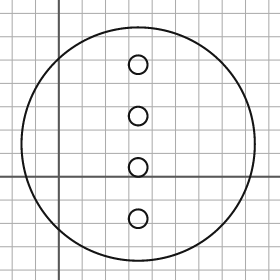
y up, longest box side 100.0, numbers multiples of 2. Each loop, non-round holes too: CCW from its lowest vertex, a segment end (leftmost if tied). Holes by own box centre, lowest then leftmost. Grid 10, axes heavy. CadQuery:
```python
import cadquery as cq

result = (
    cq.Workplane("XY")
    .moveTo(34.0, 14.0)
    .circle(50.0)
    .moveTo(34.0, -18.0)
    .circle(4.0)
    .moveTo(34.0, 4.0)
    .circle(4.0)
    .moveTo(34.0, 26.0)
    .circle(4.0)
    .moveTo(34.0, 48.0)
    .circle(4.0)
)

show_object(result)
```